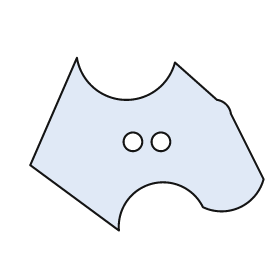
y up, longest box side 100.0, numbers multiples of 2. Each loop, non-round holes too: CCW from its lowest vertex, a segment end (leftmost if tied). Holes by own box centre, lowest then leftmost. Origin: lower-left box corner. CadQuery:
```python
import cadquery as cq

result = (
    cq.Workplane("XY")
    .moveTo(38.0, 0.0)
    .threePointArc((52.0, 20.0), (74.0, 10.0))
    .threePointArc((90.0, 10.0), (100.0, 22.0))
    .lineTo(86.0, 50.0)
    .threePointArc((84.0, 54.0), (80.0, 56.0))
    .lineTo(62.0, 72.0)
    .threePointArc((40.0, 56.0), (20.0, 74.0))
    .lineTo(0.0, 28.0)
    .close()
    .moveTo(44.0, 38.0)
    .circle(4.0)
    .moveTo(56.0, 38.0)
    .circle(4.0)
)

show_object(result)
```